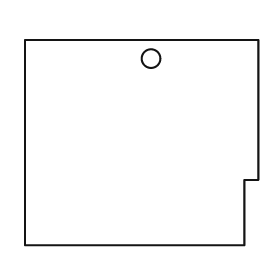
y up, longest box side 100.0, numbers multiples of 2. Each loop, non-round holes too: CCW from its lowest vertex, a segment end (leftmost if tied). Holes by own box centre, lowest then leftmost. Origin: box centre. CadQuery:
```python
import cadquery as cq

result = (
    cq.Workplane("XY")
    .moveTo(-50.0, -44.0)
    .lineTo(44.0, -44.0)
    .lineTo(44.0, -16.0)
    .lineTo(50.0, -16.0)
    .lineTo(50.0, 44.0)
    .lineTo(-50.0, 44.0)
    .close()
    .moveTo(4.0, 36.0)
    .circle(4.0)
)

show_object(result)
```